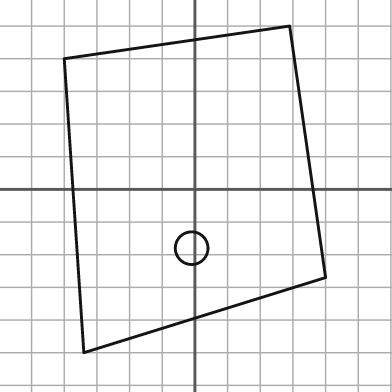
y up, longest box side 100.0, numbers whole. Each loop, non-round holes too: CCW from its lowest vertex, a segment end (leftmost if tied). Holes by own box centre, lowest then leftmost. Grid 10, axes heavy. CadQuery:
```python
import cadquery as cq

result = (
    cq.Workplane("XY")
    .moveTo(-34.0, -50.0)
    .lineTo(40.0, -27.0)
    .lineTo(29.0, 50.0)
    .lineTo(-40.0, 40.0)
    .close()
    .moveTo(-1.0, -18.0)
    .circle(5.0)
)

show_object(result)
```